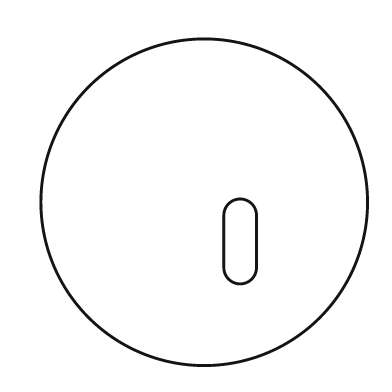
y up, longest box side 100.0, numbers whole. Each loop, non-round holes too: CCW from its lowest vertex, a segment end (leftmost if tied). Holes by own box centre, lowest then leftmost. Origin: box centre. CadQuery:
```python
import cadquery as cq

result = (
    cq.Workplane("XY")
    .moveTo(0.0, 0.0)
    .circle(50.0)
    .moveTo(6.0, -20.0)
    .threePointArc((11.0, -25.0), (16.0, -20.0))
    .lineTo(16.0, -4.0)
    .threePointArc((11.0, 1.0), (6.0, -4.0))
    .close()
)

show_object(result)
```